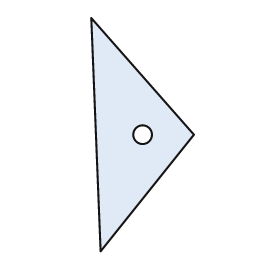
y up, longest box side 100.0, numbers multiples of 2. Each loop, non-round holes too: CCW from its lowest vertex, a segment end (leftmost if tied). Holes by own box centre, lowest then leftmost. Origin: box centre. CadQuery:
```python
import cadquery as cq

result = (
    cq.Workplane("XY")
    .moveTo(-18.0, -50.0)
    .lineTo(22.0, 0.0)
    .lineTo(-22.0, 50.0)
    .close()
    .moveTo(0.0, 0.0)
    .circle(4.0)
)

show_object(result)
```